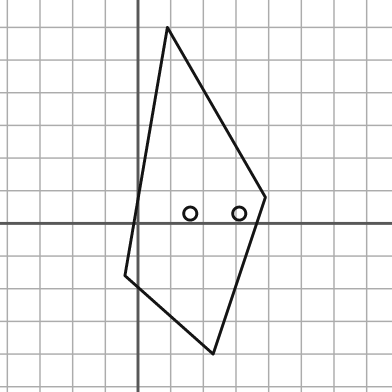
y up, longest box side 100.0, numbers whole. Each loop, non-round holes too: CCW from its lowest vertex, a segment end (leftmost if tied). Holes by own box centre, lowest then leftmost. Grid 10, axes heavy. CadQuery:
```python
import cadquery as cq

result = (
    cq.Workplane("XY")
    .moveTo(23.0, -40.0)
    .lineTo(39.0, 8.0)
    .lineTo(9.0, 60.0)
    .lineTo(-4.0, -16.0)
    .close()
    .moveTo(16.0, 3.0)
    .circle(2.0)
    .moveTo(31.0, 3.0)
    .circle(2.0)
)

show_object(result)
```